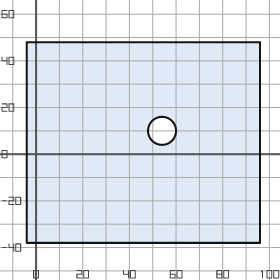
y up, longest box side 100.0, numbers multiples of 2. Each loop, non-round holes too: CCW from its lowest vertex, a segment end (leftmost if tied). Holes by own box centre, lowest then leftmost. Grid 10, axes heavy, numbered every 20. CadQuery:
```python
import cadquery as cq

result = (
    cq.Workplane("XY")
    .moveTo(-4.0, -38.0)
    .lineTo(96.0, -38.0)
    .lineTo(96.0, 48.0)
    .lineTo(-4.0, 48.0)
    .close()
    .moveTo(54.0, 10.0)
    .circle(6.0)
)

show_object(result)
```